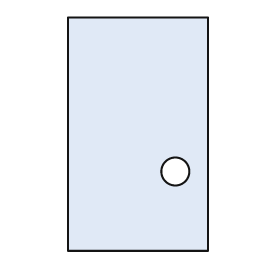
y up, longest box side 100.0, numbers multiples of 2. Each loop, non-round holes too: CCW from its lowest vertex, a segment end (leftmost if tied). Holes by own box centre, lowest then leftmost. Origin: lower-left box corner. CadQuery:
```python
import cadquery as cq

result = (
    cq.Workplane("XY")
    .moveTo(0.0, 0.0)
    .lineTo(60.0, 0.0)
    .lineTo(60.0, 100.0)
    .lineTo(0.0, 100.0)
    .close()
    .moveTo(46.0, 34.0)
    .circle(6.0)
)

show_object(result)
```